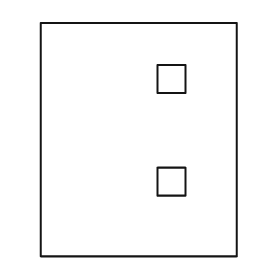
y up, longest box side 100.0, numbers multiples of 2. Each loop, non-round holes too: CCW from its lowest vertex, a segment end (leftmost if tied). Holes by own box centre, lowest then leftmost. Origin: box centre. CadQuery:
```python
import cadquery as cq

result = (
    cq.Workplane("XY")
    .moveTo(-42.0, -50.0)
    .lineTo(42.0, -50.0)
    .lineTo(42.0, 50.0)
    .lineTo(-42.0, 50.0)
    .close()
    .moveTo(8.0, -24.0)
    .lineTo(20.0, -24.0)
    .lineTo(20.0, -12.0)
    .lineTo(8.0, -12.0)
    .close()
    .moveTo(8.0, 20.0)
    .lineTo(20.0, 20.0)
    .lineTo(20.0, 32.0)
    .lineTo(8.0, 32.0)
    .close()
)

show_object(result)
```